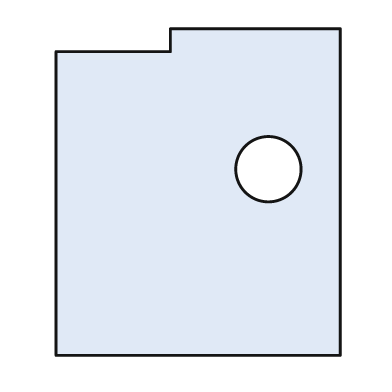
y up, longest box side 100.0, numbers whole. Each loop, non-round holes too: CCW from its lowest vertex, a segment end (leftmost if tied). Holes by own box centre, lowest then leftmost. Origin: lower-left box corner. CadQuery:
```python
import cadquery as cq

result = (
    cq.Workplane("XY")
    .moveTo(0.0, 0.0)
    .lineTo(87.0, 0.0)
    .lineTo(87.0, 100.0)
    .lineTo(35.0, 100.0)
    .lineTo(35.0, 93.0)
    .lineTo(0.0, 93.0)
    .close()
    .moveTo(65.0, 57.0)
    .circle(10.0)
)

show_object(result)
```